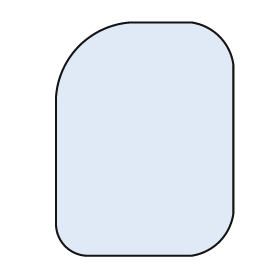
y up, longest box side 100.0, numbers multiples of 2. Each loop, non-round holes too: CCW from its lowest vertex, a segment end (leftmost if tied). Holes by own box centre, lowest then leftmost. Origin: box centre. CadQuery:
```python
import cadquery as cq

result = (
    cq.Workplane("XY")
    .moveTo(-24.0, -50.0)
    .lineTo(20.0, -50.0)
    .threePointArc((32.0, -44.0), (38.0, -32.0))
    .lineTo(38.0, 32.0)
    .threePointArc((32.0, 44.0), (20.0, 50.0))
    .lineTo(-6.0, 50.0)
    .threePointArc((-28.0, 40.0), (-38.0, 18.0))
    .lineTo(-38.0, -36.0)
    .threePointArc((-34.0, -46.0), (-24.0, -50.0))
    .close()
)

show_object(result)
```